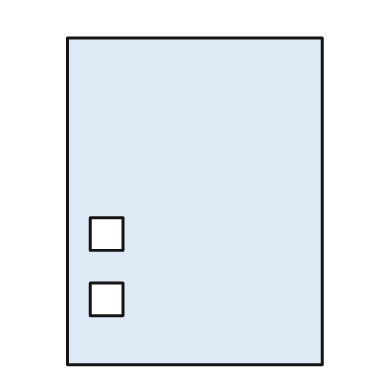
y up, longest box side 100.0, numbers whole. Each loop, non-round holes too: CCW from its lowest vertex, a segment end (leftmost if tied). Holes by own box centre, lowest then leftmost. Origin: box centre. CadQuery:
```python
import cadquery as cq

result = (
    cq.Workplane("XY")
    .moveTo(-39.0, -50.0)
    .lineTo(39.0, -50.0)
    .lineTo(39.0, 50.0)
    .lineTo(-39.0, 50.0)
    .close()
    .moveTo(-32.0, -35.0)
    .lineTo(-22.0, -35.0)
    .lineTo(-22.0, -25.0)
    .lineTo(-32.0, -25.0)
    .close()
    .moveTo(-32.0, -15.0)
    .lineTo(-22.0, -15.0)
    .lineTo(-22.0, -5.0)
    .lineTo(-32.0, -5.0)
    .close()
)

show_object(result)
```